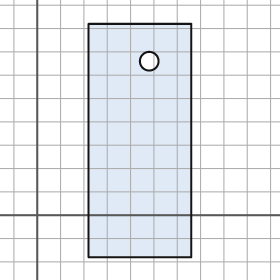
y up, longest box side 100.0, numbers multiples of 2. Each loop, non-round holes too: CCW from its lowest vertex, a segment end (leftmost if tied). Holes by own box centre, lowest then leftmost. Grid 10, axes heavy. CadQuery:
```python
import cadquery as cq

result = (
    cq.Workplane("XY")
    .moveTo(22.0, -18.0)
    .lineTo(66.0, -18.0)
    .lineTo(66.0, 82.0)
    .lineTo(22.0, 82.0)
    .close()
    .moveTo(48.0, 66.0)
    .circle(4.0)
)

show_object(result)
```